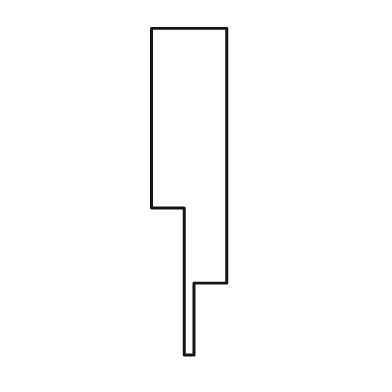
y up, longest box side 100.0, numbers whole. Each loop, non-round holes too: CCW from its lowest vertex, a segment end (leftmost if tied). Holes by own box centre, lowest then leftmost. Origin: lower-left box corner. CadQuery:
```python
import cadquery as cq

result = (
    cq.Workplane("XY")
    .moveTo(10.0, 0.0)
    .lineTo(13.0, 0.0)
    .lineTo(13.0, 22.0)
    .lineTo(23.0, 22.0)
    .lineTo(23.0, 100.0)
    .lineTo(0.0, 100.0)
    .lineTo(0.0, 45.0)
    .lineTo(10.0, 45.0)
    .close()
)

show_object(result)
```